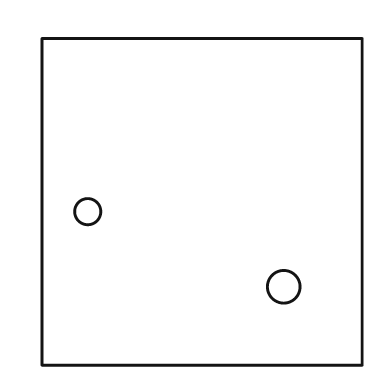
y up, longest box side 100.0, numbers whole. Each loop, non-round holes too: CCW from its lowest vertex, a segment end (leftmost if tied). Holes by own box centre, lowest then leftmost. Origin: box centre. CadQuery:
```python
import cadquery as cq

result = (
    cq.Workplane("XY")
    .moveTo(-49.0, -50.0)
    .lineTo(49.0, -50.0)
    .lineTo(49.0, 50.0)
    .lineTo(-49.0, 50.0)
    .close()
    .moveTo(25.0, -26.0)
    .circle(5.0)
    .moveTo(-35.0, -3.0)
    .circle(4.0)
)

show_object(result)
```